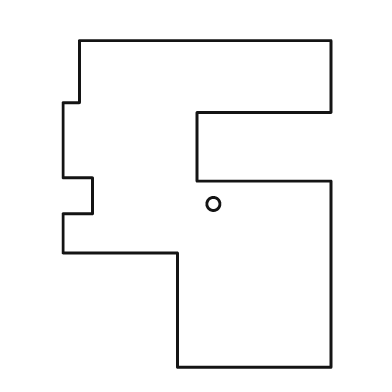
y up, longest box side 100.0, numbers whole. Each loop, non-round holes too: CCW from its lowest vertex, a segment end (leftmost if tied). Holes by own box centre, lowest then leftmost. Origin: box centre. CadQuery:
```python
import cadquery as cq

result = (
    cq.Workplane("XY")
    .moveTo(-6.0, -50.0)
    .lineTo(41.0, -50.0)
    .lineTo(41.0, 7.0)
    .lineTo(0.0, 7.0)
    .lineTo(0.0, 28.0)
    .lineTo(41.0, 28.0)
    .lineTo(41.0, 50.0)
    .lineTo(-36.0, 50.0)
    .lineTo(-36.0, 31.0)
    .lineTo(-41.0, 31.0)
    .lineTo(-41.0, 8.0)
    .lineTo(-32.0, 8.0)
    .lineTo(-32.0, -3.0)
    .lineTo(-41.0, -3.0)
    .lineTo(-41.0, -15.0)
    .lineTo(-6.0, -15.0)
    .close()
    .moveTo(5.0, 0.0)
    .circle(2.0)
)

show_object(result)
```